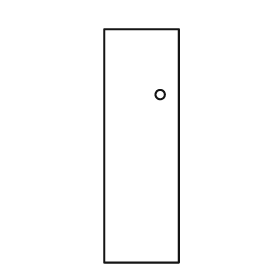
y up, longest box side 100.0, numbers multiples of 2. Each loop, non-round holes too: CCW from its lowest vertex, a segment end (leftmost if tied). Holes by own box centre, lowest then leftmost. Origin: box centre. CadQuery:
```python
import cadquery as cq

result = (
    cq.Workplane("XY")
    .moveTo(-16.0, -50.0)
    .lineTo(16.0, -50.0)
    .lineTo(16.0, 50.0)
    .lineTo(-16.0, 50.0)
    .close()
    .moveTo(8.0, 22.0)
    .circle(2.0)
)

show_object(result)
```